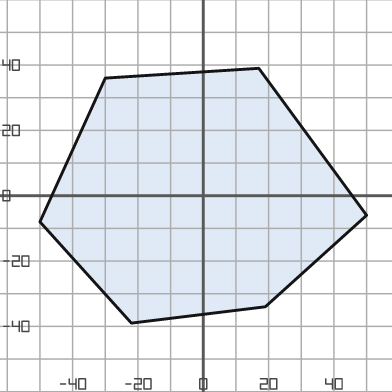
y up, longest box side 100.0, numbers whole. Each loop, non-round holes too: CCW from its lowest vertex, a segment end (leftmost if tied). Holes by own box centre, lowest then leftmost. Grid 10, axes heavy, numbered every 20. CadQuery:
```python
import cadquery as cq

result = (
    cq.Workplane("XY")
    .moveTo(-22.0, -39.0)
    .lineTo(19.0, -34.0)
    .lineTo(50.0, -6.0)
    .lineTo(17.0, 39.0)
    .lineTo(-30.0, 36.0)
    .lineTo(-50.0, -8.0)
    .close()
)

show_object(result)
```